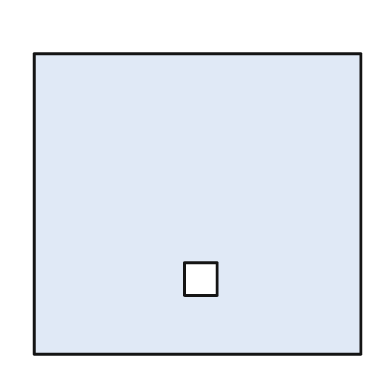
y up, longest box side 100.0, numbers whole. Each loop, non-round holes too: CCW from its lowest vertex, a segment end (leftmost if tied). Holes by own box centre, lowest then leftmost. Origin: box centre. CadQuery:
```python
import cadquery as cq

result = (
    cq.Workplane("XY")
    .moveTo(-50.0, -46.0)
    .lineTo(50.0, -46.0)
    .lineTo(50.0, 46.0)
    .lineTo(-50.0, 46.0)
    .close()
    .moveTo(-4.0, -28.0)
    .lineTo(6.0, -28.0)
    .lineTo(6.0, -18.0)
    .lineTo(-4.0, -18.0)
    .close()
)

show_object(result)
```